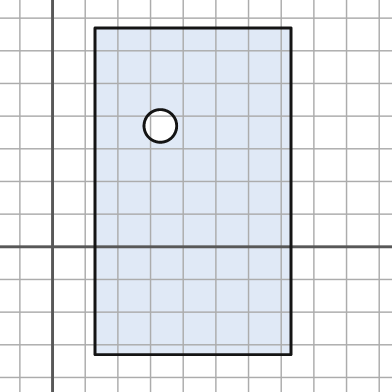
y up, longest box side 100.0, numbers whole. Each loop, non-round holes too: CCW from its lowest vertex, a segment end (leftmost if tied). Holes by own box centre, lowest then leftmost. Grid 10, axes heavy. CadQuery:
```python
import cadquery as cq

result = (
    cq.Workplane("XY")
    .moveTo(13.0, -33.0)
    .lineTo(73.0, -33.0)
    .lineTo(73.0, 67.0)
    .lineTo(13.0, 67.0)
    .close()
    .moveTo(33.0, 37.0)
    .circle(5.0)
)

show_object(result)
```